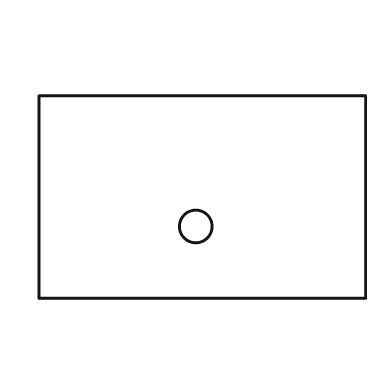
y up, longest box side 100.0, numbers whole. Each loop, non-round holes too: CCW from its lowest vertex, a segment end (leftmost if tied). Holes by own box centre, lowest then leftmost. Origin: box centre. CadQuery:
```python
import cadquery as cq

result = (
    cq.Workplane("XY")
    .moveTo(-50.0, -31.0)
    .lineTo(50.0, -31.0)
    .lineTo(50.0, 31.0)
    .lineTo(-50.0, 31.0)
    .close()
    .moveTo(-2.0, -9.0)
    .circle(5.0)
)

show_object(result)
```